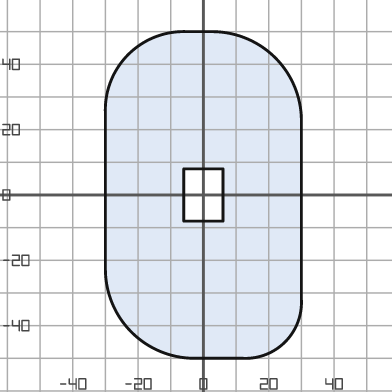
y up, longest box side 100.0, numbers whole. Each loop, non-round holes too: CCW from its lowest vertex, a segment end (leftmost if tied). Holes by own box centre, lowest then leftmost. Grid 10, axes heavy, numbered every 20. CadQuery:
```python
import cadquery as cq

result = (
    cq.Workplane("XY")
    .moveTo(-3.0, -50.0)
    .lineTo(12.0, -50.0)
    .threePointArc((25.0, -45.0), (30.0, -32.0))
    .lineTo(30.0, 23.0)
    .threePointArc((22.0, 42.0), (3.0, 50.0))
    .lineTo(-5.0, 50.0)
    .threePointArc((-23.0, 43.0), (-30.0, 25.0))
    .lineTo(-30.0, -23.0)
    .threePointArc((-22.0, -42.0), (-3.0, -50.0))
    .close()
    .moveTo(-6.0, -8.0)
    .lineTo(6.0, -8.0)
    .lineTo(6.0, 8.0)
    .lineTo(-6.0, 8.0)
    .close()
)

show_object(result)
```